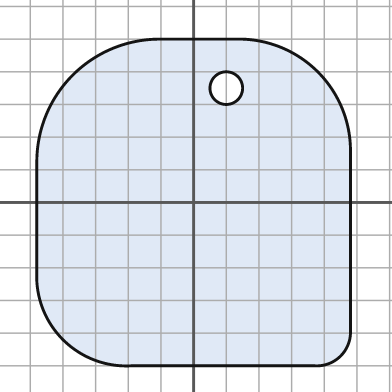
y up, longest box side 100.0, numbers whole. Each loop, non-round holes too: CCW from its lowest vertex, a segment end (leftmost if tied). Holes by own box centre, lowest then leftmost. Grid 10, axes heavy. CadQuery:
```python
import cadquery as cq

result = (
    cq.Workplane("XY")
    .moveTo(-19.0, -50.0)
    .lineTo(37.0, -50.0)
    .threePointArc((45.0, -47.0), (48.0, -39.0))
    .lineTo(48.0, 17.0)
    .threePointArc((38.0, 40.0), (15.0, 50.0))
    .lineTo(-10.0, 50.0)
    .threePointArc((-37.0, 39.0), (-48.0, 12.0))
    .lineTo(-48.0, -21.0)
    .threePointArc((-40.0, -42.0), (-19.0, -50.0))
    .close()
    .moveTo(10.0, 35.0)
    .circle(5.0)
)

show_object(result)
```